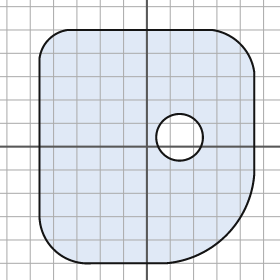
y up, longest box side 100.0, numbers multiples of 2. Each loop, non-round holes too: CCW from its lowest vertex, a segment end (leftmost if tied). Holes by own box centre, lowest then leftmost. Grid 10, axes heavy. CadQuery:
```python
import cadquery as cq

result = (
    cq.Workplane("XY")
    .moveTo(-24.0, -50.0)
    .lineTo(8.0, -50.0)
    .threePointArc((34.0, -38.0), (46.0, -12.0))
    .lineTo(46.0, 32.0)
    .threePointArc((40.0, 44.0), (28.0, 50.0))
    .lineTo(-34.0, 50.0)
    .threePointArc((-42.0, 46.0), (-46.0, 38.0))
    .lineTo(-46.0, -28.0)
    .threePointArc((-40.0, -44.0), (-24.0, -50.0))
    .close()
    .moveTo(14.0, 4.0)
    .circle(10.0)
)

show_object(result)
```